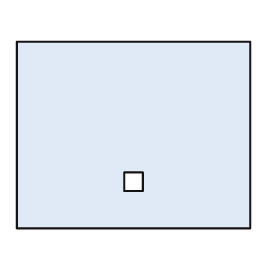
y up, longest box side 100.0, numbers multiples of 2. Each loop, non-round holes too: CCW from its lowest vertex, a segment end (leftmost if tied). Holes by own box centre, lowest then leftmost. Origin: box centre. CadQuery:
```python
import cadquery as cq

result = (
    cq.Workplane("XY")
    .moveTo(-50.0, -40.0)
    .lineTo(50.0, -40.0)
    .lineTo(50.0, 40.0)
    .lineTo(-50.0, 40.0)
    .close()
    .moveTo(-4.0, -24.0)
    .lineTo(4.0, -24.0)
    .lineTo(4.0, -16.0)
    .lineTo(-4.0, -16.0)
    .close()
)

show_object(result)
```